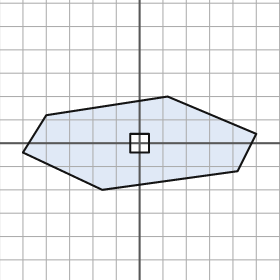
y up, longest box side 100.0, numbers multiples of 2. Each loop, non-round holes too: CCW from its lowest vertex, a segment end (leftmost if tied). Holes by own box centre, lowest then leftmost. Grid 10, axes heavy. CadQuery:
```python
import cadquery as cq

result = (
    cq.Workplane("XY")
    .moveTo(-16.0, -20.0)
    .lineTo(42.0, -12.0)
    .lineTo(50.0, 4.0)
    .lineTo(12.0, 20.0)
    .lineTo(-40.0, 12.0)
    .lineTo(-50.0, -4.0)
    .close()
    .moveTo(-4.0, -4.0)
    .lineTo(4.0, -4.0)
    .lineTo(4.0, 4.0)
    .lineTo(-4.0, 4.0)
    .close()
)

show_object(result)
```